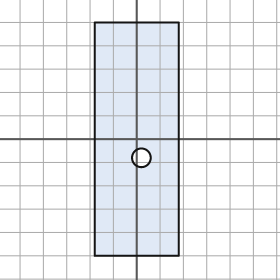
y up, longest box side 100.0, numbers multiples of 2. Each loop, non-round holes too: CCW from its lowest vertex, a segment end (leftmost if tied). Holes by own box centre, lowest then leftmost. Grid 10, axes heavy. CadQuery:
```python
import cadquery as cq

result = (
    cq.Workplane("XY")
    .moveTo(-18.0, -50.0)
    .lineTo(18.0, -50.0)
    .lineTo(18.0, 50.0)
    .lineTo(-18.0, 50.0)
    .close()
    .moveTo(2.0, -8.0)
    .circle(4.0)
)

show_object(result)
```